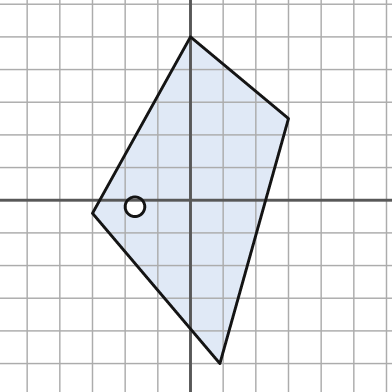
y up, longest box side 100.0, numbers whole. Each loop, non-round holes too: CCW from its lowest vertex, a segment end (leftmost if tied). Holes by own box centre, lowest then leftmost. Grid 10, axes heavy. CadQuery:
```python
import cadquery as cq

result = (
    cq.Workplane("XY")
    .moveTo(9.0, -50.0)
    .lineTo(30.0, 25.0)
    .lineTo(0.0, 50.0)
    .lineTo(-30.0, -4.0)
    .close()
    .moveTo(-17.0, -2.0)
    .circle(3.0)
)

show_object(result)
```